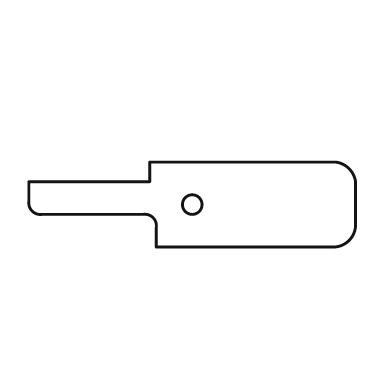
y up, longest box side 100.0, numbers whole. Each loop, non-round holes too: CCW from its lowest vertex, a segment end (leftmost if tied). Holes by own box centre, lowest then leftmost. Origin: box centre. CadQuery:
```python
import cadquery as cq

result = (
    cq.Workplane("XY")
    .moveTo(-11.0, -13.0)
    .lineTo(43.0, -13.0)
    .threePointArc((48.0, -11.0), (50.0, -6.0))
    .lineTo(50.0, 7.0)
    .threePointArc((48.0, 11.0), (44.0, 13.0))
    .lineTo(-13.0, 13.0)
    .lineTo(-13.0, 7.0)
    .lineTo(-50.0, 7.0)
    .lineTo(-50.0, 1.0)
    .threePointArc((-49.0, -2.0), (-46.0, -3.0))
    .lineTo(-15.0, -3.0)
    .threePointArc((-12.0, -4.0), (-11.0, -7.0))
    .close()
    .moveTo(0.0, 0.0)
    .circle(3.0)
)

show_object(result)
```